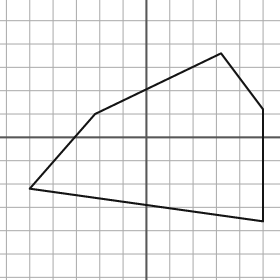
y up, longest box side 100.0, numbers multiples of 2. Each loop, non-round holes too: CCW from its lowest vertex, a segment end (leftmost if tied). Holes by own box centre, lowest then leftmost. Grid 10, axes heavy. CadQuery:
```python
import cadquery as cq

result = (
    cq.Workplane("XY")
    .moveTo(50.0, -36.0)
    .lineTo(50.0, 12.0)
    .lineTo(32.0, 36.0)
    .lineTo(-22.0, 10.0)
    .lineTo(-50.0, -22.0)
    .close()
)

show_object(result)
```